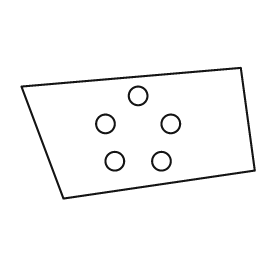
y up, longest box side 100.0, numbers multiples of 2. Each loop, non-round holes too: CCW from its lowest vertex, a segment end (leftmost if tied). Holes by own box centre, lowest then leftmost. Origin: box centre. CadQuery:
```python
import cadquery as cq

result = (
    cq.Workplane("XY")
    .moveTo(-32.0, -28.0)
    .lineTo(50.0, -16.0)
    .lineTo(44.0, 28.0)
    .lineTo(-50.0, 20.0)
    .close()
    .moveTo(-10.0, -12.0)
    .circle(4.0)
    .moveTo(10.0, -12.0)
    .circle(4.0)
    .moveTo(-14.0, 4.0)
    .circle(4.0)
    .moveTo(14.0, 4.0)
    .circle(4.0)
    .moveTo(0.0, 16.0)
    .circle(4.0)
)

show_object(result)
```